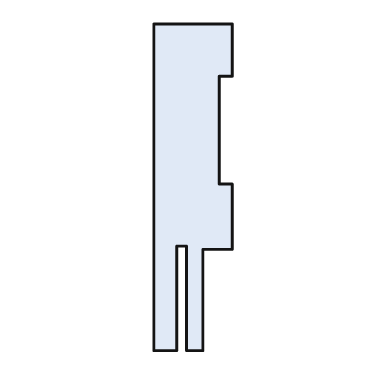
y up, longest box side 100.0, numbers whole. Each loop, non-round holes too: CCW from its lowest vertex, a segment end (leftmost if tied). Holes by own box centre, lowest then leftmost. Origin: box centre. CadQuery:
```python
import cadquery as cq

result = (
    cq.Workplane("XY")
    .moveTo(-12.0, -50.0)
    .lineTo(-5.0, -50.0)
    .lineTo(-5.0, -18.0)
    .lineTo(-2.0, -18.0)
    .lineTo(-2.0, -50.0)
    .lineTo(3.0, -50.0)
    .lineTo(3.0, -19.0)
    .lineTo(12.0, -19.0)
    .lineTo(12.0, 1.0)
    .lineTo(8.0, 1.0)
    .lineTo(8.0, 34.0)
    .lineTo(12.0, 34.0)
    .lineTo(12.0, 50.0)
    .lineTo(-12.0, 50.0)
    .close()
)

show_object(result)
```